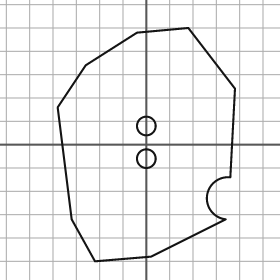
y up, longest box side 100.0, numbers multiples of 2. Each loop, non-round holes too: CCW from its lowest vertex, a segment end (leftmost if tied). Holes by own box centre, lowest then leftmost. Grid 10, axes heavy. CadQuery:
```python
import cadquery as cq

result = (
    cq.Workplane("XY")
    .moveTo(-22.0, -50.0)
    .lineTo(2.0, -48.0)
    .lineTo(34.0, -32.0)
    .threePointArc((26.0, -22.0), (36.0, -14.0))
    .lineTo(38.0, 24.0)
    .lineTo(18.0, 50.0)
    .lineTo(-4.0, 48.0)
    .lineTo(-26.0, 34.0)
    .lineTo(-38.0, 16.0)
    .lineTo(-32.0, -32.0)
    .close()
    .moveTo(0.0, -6.0)
    .circle(4.0)
    .moveTo(0.0, 8.0)
    .circle(4.0)
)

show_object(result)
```